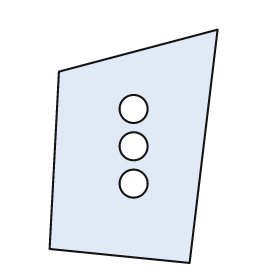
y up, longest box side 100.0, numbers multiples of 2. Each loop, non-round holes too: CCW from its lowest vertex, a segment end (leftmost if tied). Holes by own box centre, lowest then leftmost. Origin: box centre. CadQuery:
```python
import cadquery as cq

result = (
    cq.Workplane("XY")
    .moveTo(24.0, -50.0)
    .lineTo(36.0, 50.0)
    .lineTo(-32.0, 32.0)
    .lineTo(-36.0, -44.0)
    .close()
    .moveTo(0.0, -16.0)
    .circle(6.0)
    .moveTo(0.0, 0.0)
    .circle(6.0)
    .moveTo(0.0, 16.0)
    .circle(6.0)
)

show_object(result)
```